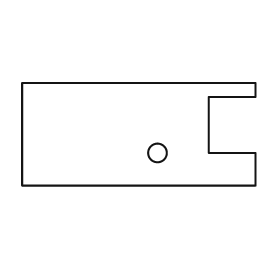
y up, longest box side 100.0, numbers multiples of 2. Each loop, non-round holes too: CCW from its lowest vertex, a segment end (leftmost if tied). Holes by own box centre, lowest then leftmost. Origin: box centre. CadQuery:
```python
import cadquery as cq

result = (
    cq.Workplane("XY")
    .moveTo(-50.0, -22.0)
    .lineTo(50.0, -22.0)
    .lineTo(50.0, -8.0)
    .lineTo(30.0, -8.0)
    .lineTo(30.0, 16.0)
    .lineTo(50.0, 16.0)
    .lineTo(50.0, 22.0)
    .lineTo(-50.0, 22.0)
    .close()
    .moveTo(8.0, -8.0)
    .circle(4.0)
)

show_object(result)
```